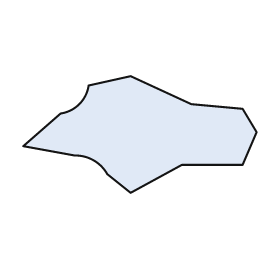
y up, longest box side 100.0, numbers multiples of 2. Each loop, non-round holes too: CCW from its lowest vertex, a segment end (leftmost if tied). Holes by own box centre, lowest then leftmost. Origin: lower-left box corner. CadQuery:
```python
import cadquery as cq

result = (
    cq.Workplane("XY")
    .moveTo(46.0, 0.0)
    .lineTo(68.0, 12.0)
    .lineTo(94.0, 12.0)
    .lineTo(100.0, 26.0)
    .lineTo(94.0, 36.0)
    .lineTo(72.0, 38.0)
    .lineTo(46.0, 50.0)
    .lineTo(28.0, 46.0)
    .threePointArc((24.0, 38.0), (16.0, 34.0))
    .lineTo(0.0, 20.0)
    .lineTo(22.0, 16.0)
    .threePointArc((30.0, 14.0), (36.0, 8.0))
    .close()
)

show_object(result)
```